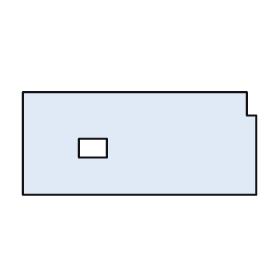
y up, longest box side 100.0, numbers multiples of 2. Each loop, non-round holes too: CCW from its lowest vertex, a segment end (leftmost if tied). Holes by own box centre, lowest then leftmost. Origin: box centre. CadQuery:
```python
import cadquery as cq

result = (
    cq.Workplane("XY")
    .moveTo(-50.0, -22.0)
    .lineTo(50.0, -22.0)
    .lineTo(50.0, 12.0)
    .lineTo(46.0, 12.0)
    .lineTo(46.0, 22.0)
    .lineTo(-50.0, 22.0)
    .close()
    .moveTo(-26.0, -6.0)
    .lineTo(-14.0, -6.0)
    .lineTo(-14.0, 2.0)
    .lineTo(-26.0, 2.0)
    .close()
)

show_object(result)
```